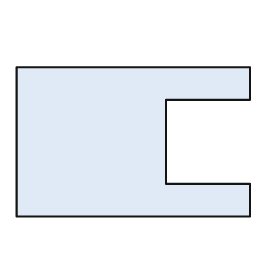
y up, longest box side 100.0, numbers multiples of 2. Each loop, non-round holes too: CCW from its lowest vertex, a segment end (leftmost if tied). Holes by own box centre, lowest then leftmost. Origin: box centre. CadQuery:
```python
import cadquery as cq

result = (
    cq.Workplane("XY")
    .moveTo(-50.0, -32.0)
    .lineTo(50.0, -32.0)
    .lineTo(50.0, -18.0)
    .lineTo(14.0, -18.0)
    .lineTo(14.0, 18.0)
    .lineTo(50.0, 18.0)
    .lineTo(50.0, 32.0)
    .lineTo(-50.0, 32.0)
    .close()
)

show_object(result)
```